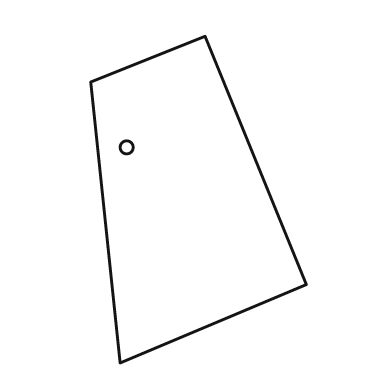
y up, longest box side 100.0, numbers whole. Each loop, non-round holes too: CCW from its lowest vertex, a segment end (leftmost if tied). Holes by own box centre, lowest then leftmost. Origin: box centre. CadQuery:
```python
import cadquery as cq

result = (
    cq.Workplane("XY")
    .moveTo(-24.0, -50.0)
    .lineTo(33.0, -26.0)
    .lineTo(2.0, 50.0)
    .lineTo(-33.0, 36.0)
    .close()
    .moveTo(-22.0, 16.0)
    .circle(2.0)
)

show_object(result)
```